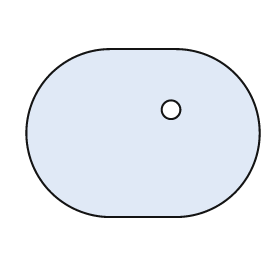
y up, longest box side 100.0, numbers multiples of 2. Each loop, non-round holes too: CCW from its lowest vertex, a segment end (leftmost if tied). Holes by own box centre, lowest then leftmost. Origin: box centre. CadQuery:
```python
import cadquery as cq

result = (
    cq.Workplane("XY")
    .moveTo(-14.0, -36.0)
    .lineTo(14.0, -36.0)
    .threePointArc((50.0, 0.0), (14.0, 36.0))
    .lineTo(-14.0, 36.0)
    .threePointArc((-50.0, 0.0), (-14.0, -36.0))
    .close()
    .moveTo(12.0, 10.0)
    .circle(4.0)
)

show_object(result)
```